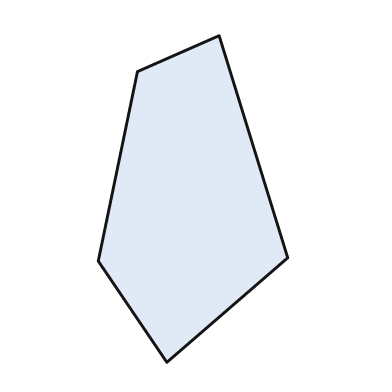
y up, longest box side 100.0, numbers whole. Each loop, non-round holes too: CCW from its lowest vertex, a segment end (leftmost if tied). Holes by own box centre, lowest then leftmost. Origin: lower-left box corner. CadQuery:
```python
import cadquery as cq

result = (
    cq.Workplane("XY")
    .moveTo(21.0, 0.0)
    .lineTo(58.0, 32.0)
    .lineTo(37.0, 100.0)
    .lineTo(12.0, 89.0)
    .lineTo(0.0, 31.0)
    .close()
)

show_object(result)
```